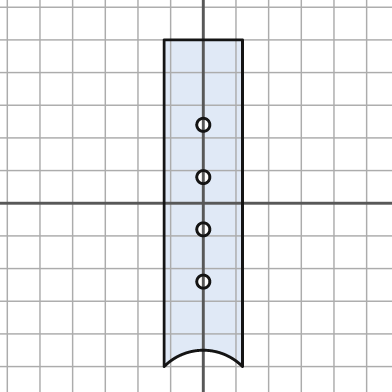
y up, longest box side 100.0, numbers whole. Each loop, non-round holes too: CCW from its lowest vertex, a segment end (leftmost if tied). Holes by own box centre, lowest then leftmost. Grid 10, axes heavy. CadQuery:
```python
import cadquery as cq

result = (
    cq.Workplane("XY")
    .moveTo(-12.0, -50.0)
    .threePointArc((0.0, -45.0), (12.0, -50.0))
    .lineTo(12.0, 50.0)
    .lineTo(-12.0, 50.0)
    .close()
    .moveTo(0.0, -24.0)
    .circle(2.0)
    .moveTo(0.0, -8.0)
    .circle(2.0)
    .moveTo(0.0, 8.0)
    .circle(2.0)
    .moveTo(0.0, 24.0)
    .circle(2.0)
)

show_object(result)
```